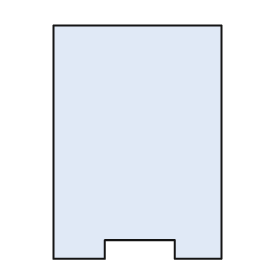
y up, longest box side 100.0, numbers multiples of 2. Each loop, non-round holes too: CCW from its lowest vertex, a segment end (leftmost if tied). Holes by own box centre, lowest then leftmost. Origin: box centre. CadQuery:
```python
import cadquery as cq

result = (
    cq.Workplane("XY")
    .moveTo(-36.0, -50.0)
    .lineTo(-14.0, -50.0)
    .lineTo(-14.0, -42.0)
    .lineTo(16.0, -42.0)
    .lineTo(16.0, -50.0)
    .lineTo(36.0, -50.0)
    .lineTo(36.0, 50.0)
    .lineTo(-36.0, 50.0)
    .close()
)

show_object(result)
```